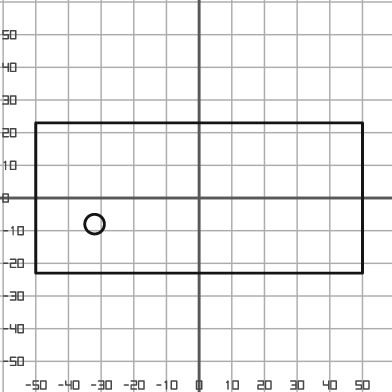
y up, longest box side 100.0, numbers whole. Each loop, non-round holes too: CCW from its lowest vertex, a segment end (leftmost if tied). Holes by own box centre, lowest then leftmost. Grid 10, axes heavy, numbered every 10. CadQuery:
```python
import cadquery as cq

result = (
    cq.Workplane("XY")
    .moveTo(-50.0, -23.0)
    .lineTo(50.0, -23.0)
    .lineTo(50.0, 23.0)
    .lineTo(-50.0, 23.0)
    .close()
    .moveTo(-32.0, -8.0)
    .circle(3.0)
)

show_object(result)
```